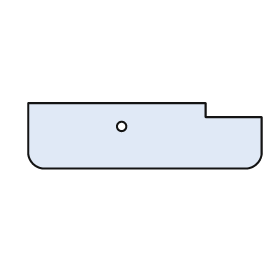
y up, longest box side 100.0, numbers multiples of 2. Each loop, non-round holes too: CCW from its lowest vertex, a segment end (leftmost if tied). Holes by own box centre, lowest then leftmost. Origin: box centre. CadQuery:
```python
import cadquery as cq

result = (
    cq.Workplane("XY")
    .moveTo(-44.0, -14.0)
    .lineTo(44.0, -14.0)
    .threePointArc((48.0, -12.0), (50.0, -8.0))
    .lineTo(50.0, 8.0)
    .lineTo(26.0, 8.0)
    .lineTo(26.0, 14.0)
    .lineTo(-50.0, 14.0)
    .lineTo(-50.0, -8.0)
    .threePointArc((-48.0, -12.0), (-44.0, -14.0))
    .close()
    .moveTo(-10.0, 4.0)
    .circle(2.0)
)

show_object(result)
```